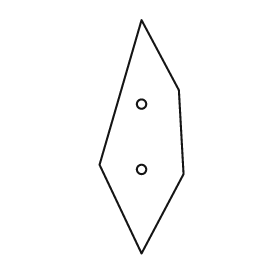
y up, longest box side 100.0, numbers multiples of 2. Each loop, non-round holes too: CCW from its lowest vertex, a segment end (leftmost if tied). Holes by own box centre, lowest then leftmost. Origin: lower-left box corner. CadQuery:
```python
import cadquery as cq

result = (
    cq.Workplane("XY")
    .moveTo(18.0, 0.0)
    .lineTo(36.0, 34.0)
    .lineTo(34.0, 70.0)
    .lineTo(18.0, 100.0)
    .lineTo(0.0, 38.0)
    .close()
    .moveTo(18.0, 36.0)
    .circle(2.0)
    .moveTo(18.0, 64.0)
    .circle(2.0)
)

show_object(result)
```